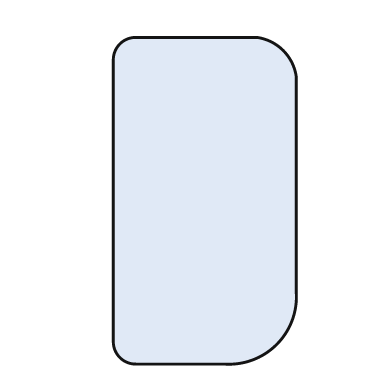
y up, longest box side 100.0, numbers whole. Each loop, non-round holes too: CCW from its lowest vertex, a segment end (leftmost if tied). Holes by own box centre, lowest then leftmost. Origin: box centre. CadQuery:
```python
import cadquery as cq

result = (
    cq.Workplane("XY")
    .moveTo(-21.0, -50.0)
    .lineTo(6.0, -50.0)
    .threePointArc((22.0, -44.0), (28.0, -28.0))
    .lineTo(28.0, 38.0)
    .threePointArc((24.0, 46.0), (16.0, 50.0))
    .lineTo(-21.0, 50.0)
    .threePointArc((-26.0, 48.0), (-28.0, 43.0))
    .lineTo(-28.0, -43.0)
    .threePointArc((-26.0, -48.0), (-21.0, -50.0))
    .close()
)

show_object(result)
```